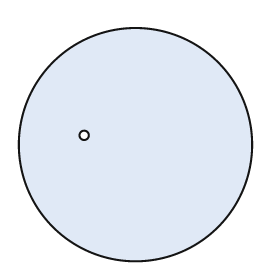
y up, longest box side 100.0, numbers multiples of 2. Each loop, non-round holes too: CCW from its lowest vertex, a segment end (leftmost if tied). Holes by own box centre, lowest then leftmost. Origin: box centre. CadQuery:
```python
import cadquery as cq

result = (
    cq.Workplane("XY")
    .moveTo(0.0, 0.0)
    .circle(50.0)
    .moveTo(-22.0, 4.0)
    .circle(2.0)
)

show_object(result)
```